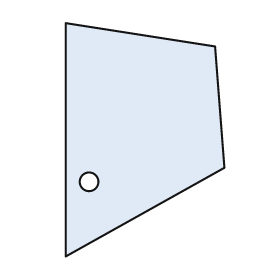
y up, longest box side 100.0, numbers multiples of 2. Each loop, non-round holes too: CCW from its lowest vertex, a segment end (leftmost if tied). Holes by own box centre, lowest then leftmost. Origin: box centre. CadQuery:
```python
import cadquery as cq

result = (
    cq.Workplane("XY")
    .moveTo(-34.0, -50.0)
    .lineTo(34.0, -12.0)
    .lineTo(30.0, 40.0)
    .lineTo(-34.0, 50.0)
    .close()
    .moveTo(-24.0, -18.0)
    .circle(4.0)
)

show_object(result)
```